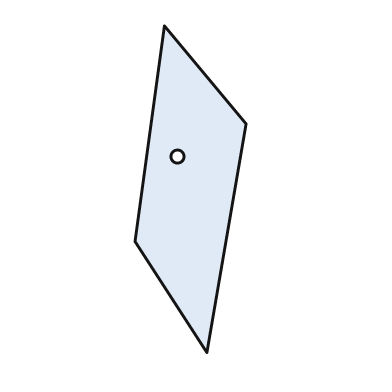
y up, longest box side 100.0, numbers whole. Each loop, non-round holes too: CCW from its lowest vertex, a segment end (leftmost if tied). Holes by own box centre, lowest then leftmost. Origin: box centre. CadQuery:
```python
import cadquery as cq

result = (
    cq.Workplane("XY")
    .moveTo(5.0, -50.0)
    .lineTo(17.0, 20.0)
    .lineTo(-8.0, 50.0)
    .lineTo(-17.0, -16.0)
    .close()
    .moveTo(-4.0, 10.0)
    .circle(2.0)
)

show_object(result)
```